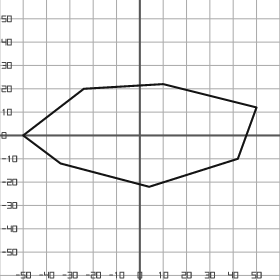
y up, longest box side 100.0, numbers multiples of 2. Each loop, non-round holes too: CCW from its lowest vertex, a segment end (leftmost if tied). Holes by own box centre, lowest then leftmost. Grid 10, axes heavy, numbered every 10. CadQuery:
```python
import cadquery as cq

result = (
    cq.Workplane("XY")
    .moveTo(4.0, -22.0)
    .lineTo(42.0, -10.0)
    .lineTo(50.0, 12.0)
    .lineTo(10.0, 22.0)
    .lineTo(-24.0, 20.0)
    .lineTo(-50.0, 0.0)
    .lineTo(-34.0, -12.0)
    .close()
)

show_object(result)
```